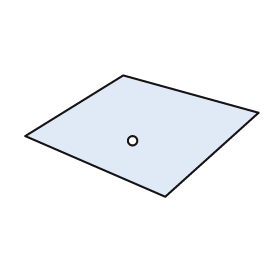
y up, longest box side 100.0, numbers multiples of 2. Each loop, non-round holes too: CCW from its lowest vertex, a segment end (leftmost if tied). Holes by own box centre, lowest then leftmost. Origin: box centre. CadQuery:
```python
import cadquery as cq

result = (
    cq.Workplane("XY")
    .moveTo(10.0, -26.0)
    .lineTo(50.0, 10.0)
    .lineTo(-8.0, 26.0)
    .lineTo(-50.0, 0.0)
    .close()
    .moveTo(-4.0, -2.0)
    .circle(2.0)
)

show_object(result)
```